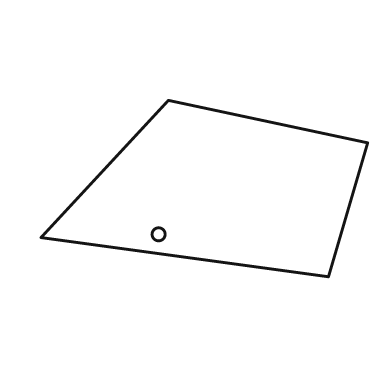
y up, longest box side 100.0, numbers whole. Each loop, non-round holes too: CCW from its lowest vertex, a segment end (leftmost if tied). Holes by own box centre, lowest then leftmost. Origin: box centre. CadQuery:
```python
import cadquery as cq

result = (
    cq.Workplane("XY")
    .moveTo(38.0, -27.0)
    .lineTo(50.0, 14.0)
    .lineTo(-11.0, 27.0)
    .lineTo(-50.0, -15.0)
    .close()
    .moveTo(-14.0, -14.0)
    .circle(2.0)
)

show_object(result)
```